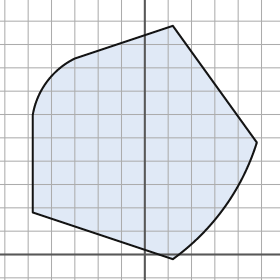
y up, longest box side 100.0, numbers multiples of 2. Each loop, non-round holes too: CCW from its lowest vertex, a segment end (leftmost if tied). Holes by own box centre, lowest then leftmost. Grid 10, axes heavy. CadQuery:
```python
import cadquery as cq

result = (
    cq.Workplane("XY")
    .moveTo(12.0, -2.0)
    .threePointArc((34.0, 20.0), (48.0, 48.0))
    .lineTo(12.0, 98.0)
    .lineTo(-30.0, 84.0)
    .threePointArc((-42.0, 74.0), (-48.0, 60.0))
    .lineTo(-48.0, 18.0)
    .close()
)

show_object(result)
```